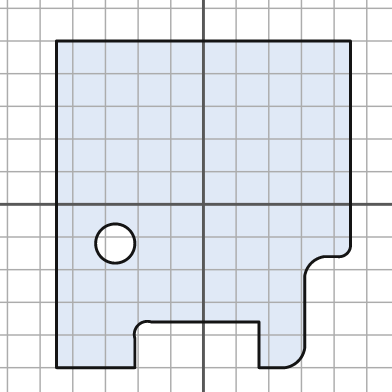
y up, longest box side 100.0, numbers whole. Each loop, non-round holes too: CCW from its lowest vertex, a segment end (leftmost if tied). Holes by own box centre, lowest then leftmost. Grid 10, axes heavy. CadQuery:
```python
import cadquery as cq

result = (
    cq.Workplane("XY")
    .moveTo(-45.0, -50.0)
    .lineTo(-21.0, -50.0)
    .lineTo(-21.0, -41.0)
    .threePointArc((-20.0, -37.0), (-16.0, -36.0))
    .lineTo(17.0, -36.0)
    .lineTo(17.0, -50.0)
    .lineTo(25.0, -50.0)
    .threePointArc((29.0, -48.0), (31.0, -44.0))
    .lineTo(31.0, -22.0)
    .threePointArc((33.0, -18.0), (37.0, -16.0))
    .lineTo(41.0, -16.0)
    .threePointArc((44.0, -15.0), (45.0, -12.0))
    .lineTo(45.0, 50.0)
    .lineTo(-45.0, 50.0)
    .close()
    .moveTo(-27.0, -12.0)
    .circle(6.0)
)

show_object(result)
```